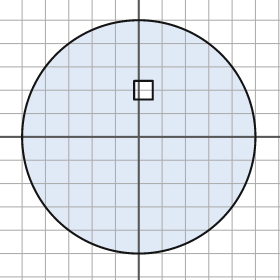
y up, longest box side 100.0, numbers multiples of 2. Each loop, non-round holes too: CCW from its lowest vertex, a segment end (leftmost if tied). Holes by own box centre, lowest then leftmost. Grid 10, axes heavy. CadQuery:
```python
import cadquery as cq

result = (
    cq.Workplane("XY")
    .moveTo(0.0, 0.0)
    .circle(50.0)
    .moveTo(-2.0, 16.0)
    .lineTo(6.0, 16.0)
    .lineTo(6.0, 24.0)
    .lineTo(-2.0, 24.0)
    .close()
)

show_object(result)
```